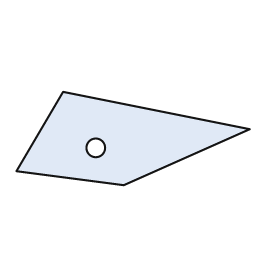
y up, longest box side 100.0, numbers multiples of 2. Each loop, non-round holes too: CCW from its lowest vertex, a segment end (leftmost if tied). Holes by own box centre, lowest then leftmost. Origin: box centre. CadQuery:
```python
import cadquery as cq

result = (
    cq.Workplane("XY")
    .moveTo(-4.0, -20.0)
    .lineTo(50.0, 4.0)
    .lineTo(-30.0, 20.0)
    .lineTo(-50.0, -14.0)
    .close()
    .moveTo(-16.0, -4.0)
    .circle(4.0)
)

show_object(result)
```